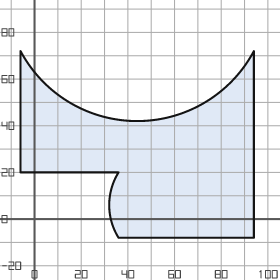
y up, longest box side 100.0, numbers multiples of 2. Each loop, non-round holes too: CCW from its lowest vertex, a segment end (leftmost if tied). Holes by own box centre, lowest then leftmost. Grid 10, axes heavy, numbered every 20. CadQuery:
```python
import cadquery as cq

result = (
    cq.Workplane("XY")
    .moveTo(36.0, -8.0)
    .lineTo(94.0, -8.0)
    .lineTo(94.0, 72.0)
    .threePointArc((44.0, 42.0), (-6.0, 72.0))
    .lineTo(-6.0, 20.0)
    .lineTo(36.0, 20.0)
    .threePointArc((32.0, 6.0), (36.0, -8.0))
    .close()
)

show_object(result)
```